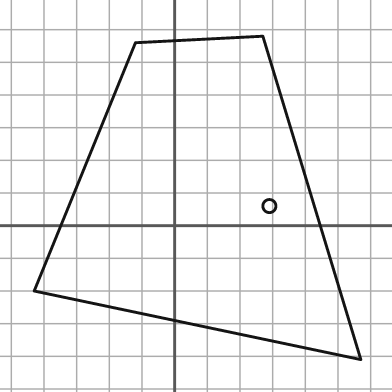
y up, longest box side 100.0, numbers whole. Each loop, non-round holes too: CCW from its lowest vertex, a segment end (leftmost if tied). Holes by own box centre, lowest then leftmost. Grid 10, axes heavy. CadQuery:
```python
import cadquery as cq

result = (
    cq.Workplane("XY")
    .moveTo(57.0, -41.0)
    .lineTo(27.0, 58.0)
    .lineTo(-12.0, 56.0)
    .lineTo(-43.0, -20.0)
    .close()
    .moveTo(29.0, 6.0)
    .circle(2.0)
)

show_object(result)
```